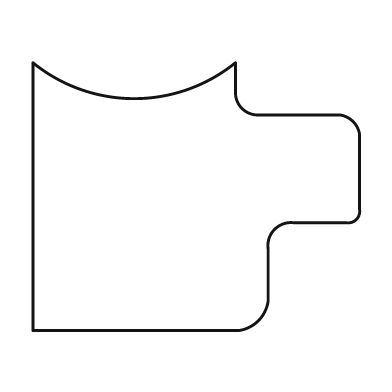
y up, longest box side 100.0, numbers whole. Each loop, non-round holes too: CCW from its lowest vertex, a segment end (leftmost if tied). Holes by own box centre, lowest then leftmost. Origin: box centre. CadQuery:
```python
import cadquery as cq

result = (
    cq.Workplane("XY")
    .moveTo(-50.0, -41.0)
    .lineTo(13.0, -41.0)
    .threePointArc((19.0, -38.0), (22.0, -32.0))
    .lineTo(22.0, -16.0)
    .threePointArc((24.0, -10.0), (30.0, -8.0))
    .lineTo(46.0, -8.0)
    .threePointArc((49.0, -7.0), (50.0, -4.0))
    .lineTo(50.0, 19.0)
    .threePointArc((48.0, 23.0), (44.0, 25.0))
    .lineTo(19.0, 25.0)
    .threePointArc((14.0, 27.0), (12.0, 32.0))
    .lineTo(12.0, 41.0)
    .threePointArc((-19.0, 30.0), (-50.0, 41.0))
    .close()
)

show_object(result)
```